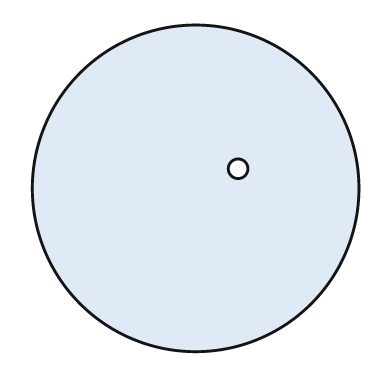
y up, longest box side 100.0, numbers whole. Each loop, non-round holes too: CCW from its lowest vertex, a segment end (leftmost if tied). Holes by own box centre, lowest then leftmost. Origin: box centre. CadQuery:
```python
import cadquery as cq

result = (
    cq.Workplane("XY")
    .moveTo(0.0, 0.0)
    .circle(50.0)
    .moveTo(13.0, 6.0)
    .circle(3.0)
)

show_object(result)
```